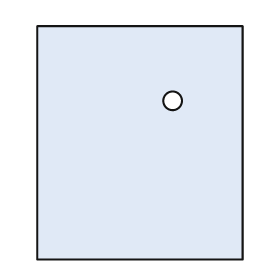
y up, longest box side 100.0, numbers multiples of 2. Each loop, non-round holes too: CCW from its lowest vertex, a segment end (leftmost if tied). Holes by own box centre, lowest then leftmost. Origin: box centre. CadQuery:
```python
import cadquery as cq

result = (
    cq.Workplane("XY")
    .moveTo(-44.0, -50.0)
    .lineTo(44.0, -50.0)
    .lineTo(44.0, 50.0)
    .lineTo(-44.0, 50.0)
    .close()
    .moveTo(14.0, 18.0)
    .circle(4.0)
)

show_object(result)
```